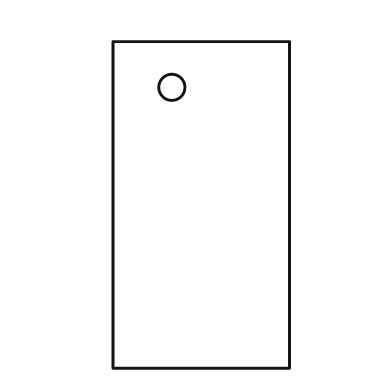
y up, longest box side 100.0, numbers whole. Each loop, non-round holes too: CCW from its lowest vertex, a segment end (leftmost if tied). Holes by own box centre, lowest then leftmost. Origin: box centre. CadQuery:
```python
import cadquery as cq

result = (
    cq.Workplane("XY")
    .moveTo(-27.0, -50.0)
    .lineTo(27.0, -50.0)
    .lineTo(27.0, 50.0)
    .lineTo(-27.0, 50.0)
    .close()
    .moveTo(-9.0, 36.0)
    .circle(4.0)
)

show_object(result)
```